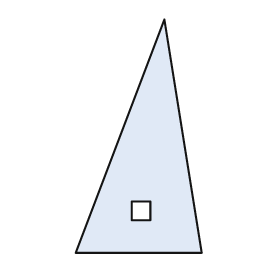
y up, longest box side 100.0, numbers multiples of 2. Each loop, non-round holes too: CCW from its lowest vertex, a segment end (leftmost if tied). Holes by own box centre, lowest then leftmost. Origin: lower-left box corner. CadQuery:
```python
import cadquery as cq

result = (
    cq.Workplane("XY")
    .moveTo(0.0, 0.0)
    .lineTo(54.0, 0.0)
    .lineTo(38.0, 100.0)
    .close()
    .moveTo(24.0, 14.0)
    .lineTo(32.0, 14.0)
    .lineTo(32.0, 22.0)
    .lineTo(24.0, 22.0)
    .close()
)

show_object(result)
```